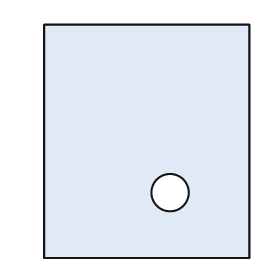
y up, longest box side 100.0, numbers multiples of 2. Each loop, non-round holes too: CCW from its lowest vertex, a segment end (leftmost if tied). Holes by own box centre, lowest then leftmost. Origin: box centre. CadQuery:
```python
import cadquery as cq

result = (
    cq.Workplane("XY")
    .moveTo(-44.0, -50.0)
    .lineTo(44.0, -50.0)
    .lineTo(44.0, 50.0)
    .lineTo(-44.0, 50.0)
    .close()
    .moveTo(10.0, -22.0)
    .circle(8.0)
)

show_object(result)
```